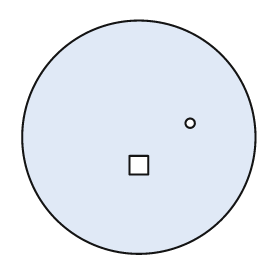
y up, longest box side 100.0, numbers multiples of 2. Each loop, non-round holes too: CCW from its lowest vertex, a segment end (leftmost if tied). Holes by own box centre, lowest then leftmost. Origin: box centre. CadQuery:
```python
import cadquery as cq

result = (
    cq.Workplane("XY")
    .moveTo(0.0, 0.0)
    .circle(50.0)
    .moveTo(-4.0, -16.0)
    .lineTo(4.0, -16.0)
    .lineTo(4.0, -8.0)
    .lineTo(-4.0, -8.0)
    .close()
    .moveTo(22.0, 6.0)
    .circle(2.0)
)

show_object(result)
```